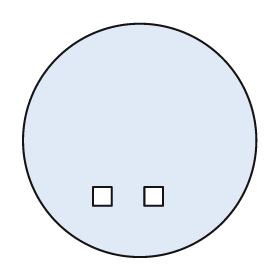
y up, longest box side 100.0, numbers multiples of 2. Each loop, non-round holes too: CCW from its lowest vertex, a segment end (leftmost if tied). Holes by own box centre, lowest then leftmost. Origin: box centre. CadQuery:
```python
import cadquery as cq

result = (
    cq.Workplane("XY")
    .moveTo(0.0, 0.0)
    .circle(50.0)
    .moveTo(-20.0, -28.0)
    .lineTo(-12.0, -28.0)
    .lineTo(-12.0, -20.0)
    .lineTo(-20.0, -20.0)
    .close()
    .moveTo(2.0, -28.0)
    .lineTo(10.0, -28.0)
    .lineTo(10.0, -20.0)
    .lineTo(2.0, -20.0)
    .close()
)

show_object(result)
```